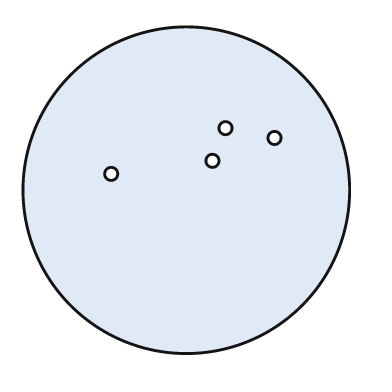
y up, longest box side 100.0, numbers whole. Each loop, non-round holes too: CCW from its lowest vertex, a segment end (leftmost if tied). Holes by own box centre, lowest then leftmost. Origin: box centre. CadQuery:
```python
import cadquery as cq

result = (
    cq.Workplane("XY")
    .moveTo(0.0, 0.0)
    .circle(50.0)
    .moveTo(-23.0, 5.0)
    .circle(2.0)
    .moveTo(8.0, 9.0)
    .circle(2.0)
    .moveTo(27.0, 16.0)
    .circle(2.0)
    .moveTo(12.0, 19.0)
    .circle(2.0)
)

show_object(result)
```